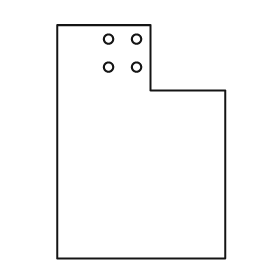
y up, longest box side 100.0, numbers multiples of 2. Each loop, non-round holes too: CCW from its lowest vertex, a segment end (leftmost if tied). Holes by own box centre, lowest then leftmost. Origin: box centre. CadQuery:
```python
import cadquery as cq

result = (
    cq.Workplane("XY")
    .moveTo(-36.0, -50.0)
    .lineTo(36.0, -50.0)
    .lineTo(36.0, 22.0)
    .lineTo(4.0, 22.0)
    .lineTo(4.0, 50.0)
    .lineTo(-36.0, 50.0)
    .close()
    .moveTo(-14.0, 32.0)
    .circle(2.0)
    .moveTo(-2.0, 32.0)
    .circle(2.0)
    .moveTo(-14.0, 44.0)
    .circle(2.0)
    .moveTo(-2.0, 44.0)
    .circle(2.0)
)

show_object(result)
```